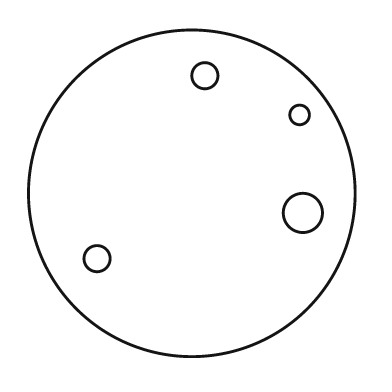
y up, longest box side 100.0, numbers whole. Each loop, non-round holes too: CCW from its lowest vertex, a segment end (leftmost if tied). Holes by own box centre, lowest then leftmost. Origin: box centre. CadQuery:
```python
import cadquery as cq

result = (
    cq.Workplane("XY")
    .moveTo(0.0, 0.0)
    .circle(50.0)
    .moveTo(-29.0, -20.0)
    .circle(4.0)
    .moveTo(34.0, -6.0)
    .circle(6.0)
    .moveTo(33.0, 24.0)
    .circle(3.0)
    .moveTo(4.0, 36.0)
    .circle(4.0)
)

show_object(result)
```